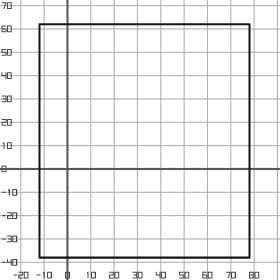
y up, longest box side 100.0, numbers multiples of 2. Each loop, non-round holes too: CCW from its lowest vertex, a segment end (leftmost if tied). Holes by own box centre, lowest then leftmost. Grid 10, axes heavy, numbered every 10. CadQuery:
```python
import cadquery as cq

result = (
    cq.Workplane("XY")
    .moveTo(-12.0, -38.0)
    .lineTo(78.0, -38.0)
    .lineTo(78.0, 62.0)
    .lineTo(-12.0, 62.0)
    .close()
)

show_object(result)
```